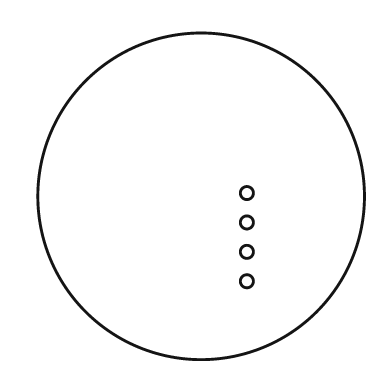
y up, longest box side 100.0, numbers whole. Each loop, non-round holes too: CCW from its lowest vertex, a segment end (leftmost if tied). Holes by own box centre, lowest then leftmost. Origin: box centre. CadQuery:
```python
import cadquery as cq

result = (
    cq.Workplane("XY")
    .moveTo(0.0, 0.0)
    .circle(50.0)
    .moveTo(14.0, -26.0)
    .circle(2.0)
    .moveTo(14.0, -17.0)
    .circle(2.0)
    .moveTo(14.0, -8.0)
    .circle(2.0)
    .moveTo(14.0, 1.0)
    .circle(2.0)
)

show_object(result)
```